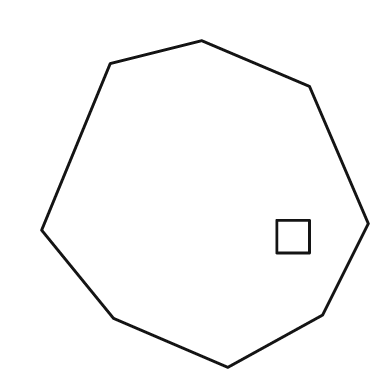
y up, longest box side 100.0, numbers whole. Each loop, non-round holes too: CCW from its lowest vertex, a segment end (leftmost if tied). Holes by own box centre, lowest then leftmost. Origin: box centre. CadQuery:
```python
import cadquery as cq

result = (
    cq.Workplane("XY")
    .moveTo(7.0, -50.0)
    .lineTo(36.0, -34.0)
    .lineTo(50.0, -6.0)
    .lineTo(32.0, 36.0)
    .lineTo(-1.0, 50.0)
    .lineTo(-29.0, 43.0)
    .lineTo(-50.0, -8.0)
    .lineTo(-28.0, -35.0)
    .close()
    .moveTo(22.0, -15.0)
    .lineTo(32.0, -15.0)
    .lineTo(32.0, -5.0)
    .lineTo(22.0, -5.0)
    .close()
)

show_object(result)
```